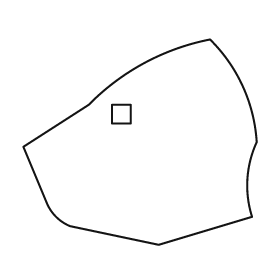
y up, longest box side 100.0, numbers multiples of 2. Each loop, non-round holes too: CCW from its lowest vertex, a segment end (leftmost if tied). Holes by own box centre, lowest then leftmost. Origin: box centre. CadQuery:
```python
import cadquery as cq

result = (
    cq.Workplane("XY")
    .moveTo(8.0, -44.0)
    .lineTo(48.0, -32.0)
    .threePointArc((46.0, -16.0), (50.0, 0.0))
    .threePointArc((44.0, 24.0), (30.0, 44.0))
    .threePointArc((2.0, 34.0), (-22.0, 16.0))
    .lineTo(-50.0, -2.0)
    .lineTo(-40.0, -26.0)
    .threePointArc((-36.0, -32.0), (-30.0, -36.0))
    .close()
    .moveTo(-12.0, 8.0)
    .lineTo(-4.0, 8.0)
    .lineTo(-4.0, 16.0)
    .lineTo(-12.0, 16.0)
    .close()
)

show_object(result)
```